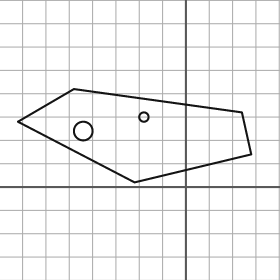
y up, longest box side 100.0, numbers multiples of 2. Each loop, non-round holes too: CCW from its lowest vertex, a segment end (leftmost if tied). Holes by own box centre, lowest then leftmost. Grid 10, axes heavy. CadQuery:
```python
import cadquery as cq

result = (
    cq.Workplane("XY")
    .moveTo(-22.0, 2.0)
    .lineTo(28.0, 14.0)
    .lineTo(24.0, 32.0)
    .lineTo(-48.0, 42.0)
    .lineTo(-72.0, 28.0)
    .close()
    .moveTo(-44.0, 24.0)
    .circle(4.0)
    .moveTo(-18.0, 30.0)
    .circle(2.0)
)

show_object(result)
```